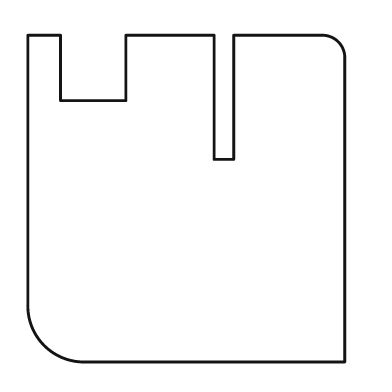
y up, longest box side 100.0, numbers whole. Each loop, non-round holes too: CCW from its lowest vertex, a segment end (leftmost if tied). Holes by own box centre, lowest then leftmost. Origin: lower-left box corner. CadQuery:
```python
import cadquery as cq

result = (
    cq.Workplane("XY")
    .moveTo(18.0, 0.0)
    .lineTo(97.0, 0.0)
    .lineTo(97.0, 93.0)
    .threePointArc((95.0, 98.0), (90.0, 100.0))
    .lineTo(63.0, 100.0)
    .lineTo(63.0, 62.0)
    .lineTo(57.0, 62.0)
    .lineTo(57.0, 100.0)
    .lineTo(30.0, 100.0)
    .lineTo(30.0, 80.0)
    .lineTo(10.0, 80.0)
    .lineTo(10.0, 100.0)
    .lineTo(0.0, 100.0)
    .lineTo(0.0, 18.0)
    .threePointArc((5.0, 5.0), (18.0, 0.0))
    .close()
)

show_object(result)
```